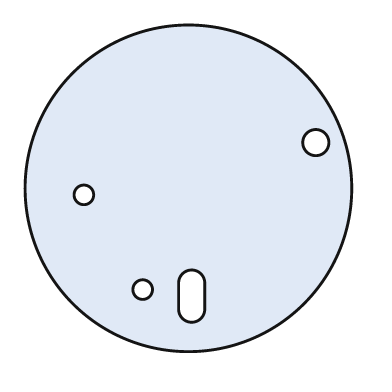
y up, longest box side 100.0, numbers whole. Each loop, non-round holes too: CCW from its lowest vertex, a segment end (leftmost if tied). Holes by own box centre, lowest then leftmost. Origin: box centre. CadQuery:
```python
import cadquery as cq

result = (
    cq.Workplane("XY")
    .moveTo(0.0, 0.0)
    .circle(50.0)
    .moveTo(-3.0, -37.0)
    .threePointArc((1.0, -41.0), (5.0, -37.0))
    .lineTo(5.0, -29.0)
    .threePointArc((1.0, -25.0), (-3.0, -29.0))
    .close()
    .moveTo(-14.0, -31.0)
    .circle(3.0)
    .moveTo(-32.0, -2.0)
    .circle(3.0)
    .moveTo(39.0, 14.0)
    .circle(4.0)
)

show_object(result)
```